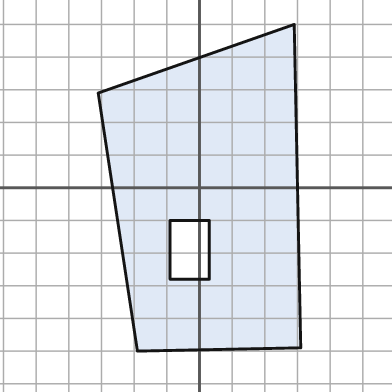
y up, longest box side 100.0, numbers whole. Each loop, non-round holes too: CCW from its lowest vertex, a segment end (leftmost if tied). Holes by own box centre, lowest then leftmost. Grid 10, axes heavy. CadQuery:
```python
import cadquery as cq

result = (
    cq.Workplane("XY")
    .moveTo(-19.0, -50.0)
    .lineTo(31.0, -49.0)
    .lineTo(29.0, 50.0)
    .lineTo(-31.0, 29.0)
    .close()
    .moveTo(-9.0, -28.0)
    .lineTo(3.0, -28.0)
    .lineTo(3.0, -10.0)
    .lineTo(-9.0, -10.0)
    .close()
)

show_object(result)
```